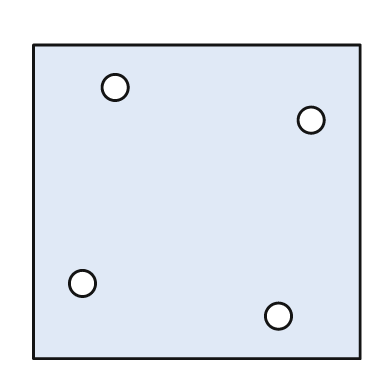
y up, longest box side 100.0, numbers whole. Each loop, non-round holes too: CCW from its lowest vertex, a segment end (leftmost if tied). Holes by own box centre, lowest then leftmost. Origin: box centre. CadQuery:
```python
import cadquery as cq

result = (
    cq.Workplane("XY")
    .moveTo(-50.0, -48.0)
    .lineTo(50.0, -48.0)
    .lineTo(50.0, 48.0)
    .lineTo(-50.0, 48.0)
    .close()
    .moveTo(25.0, -35.0)
    .circle(4.0)
    .moveTo(-35.0, -25.0)
    .circle(4.0)
    .moveTo(35.0, 25.0)
    .circle(4.0)
    .moveTo(-25.0, 35.0)
    .circle(4.0)
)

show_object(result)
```